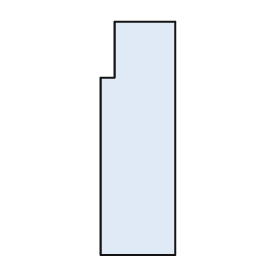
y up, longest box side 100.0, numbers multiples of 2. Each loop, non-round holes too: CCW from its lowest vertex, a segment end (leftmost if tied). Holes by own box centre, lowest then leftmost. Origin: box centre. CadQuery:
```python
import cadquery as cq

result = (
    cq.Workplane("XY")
    .moveTo(-16.0, -50.0)
    .lineTo(16.0, -50.0)
    .lineTo(16.0, 50.0)
    .lineTo(-10.0, 50.0)
    .lineTo(-10.0, 26.0)
    .lineTo(-16.0, 26.0)
    .close()
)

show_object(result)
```